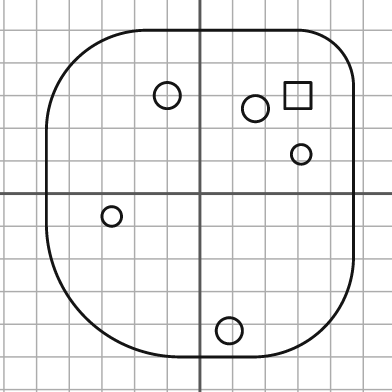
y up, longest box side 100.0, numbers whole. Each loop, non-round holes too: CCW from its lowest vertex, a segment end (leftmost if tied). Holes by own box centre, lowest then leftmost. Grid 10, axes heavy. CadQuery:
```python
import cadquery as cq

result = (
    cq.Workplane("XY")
    .moveTo(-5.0, -50.0)
    .lineTo(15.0, -50.0)
    .threePointArc((38.0, -41.0), (47.0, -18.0))
    .lineTo(47.0, 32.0)
    .threePointArc((42.0, 45.0), (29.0, 50.0))
    .lineTo(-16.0, 50.0)
    .threePointArc((-38.0, 41.0), (-47.0, 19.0))
    .lineTo(-47.0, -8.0)
    .threePointArc((-35.0, -38.0), (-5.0, -50.0))
    .close()
    .moveTo(9.0, -42.0)
    .circle(4.0)
    .moveTo(-27.0, -7.0)
    .circle(3.0)
    .moveTo(31.0, 12.0)
    .circle(3.0)
    .moveTo(17.0, 26.0)
    .circle(4.0)
    .moveTo(-10.0, 30.0)
    .circle(4.0)
    .moveTo(26.0, 26.0)
    .lineTo(34.0, 26.0)
    .lineTo(34.0, 34.0)
    .lineTo(26.0, 34.0)
    .close()
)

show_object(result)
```